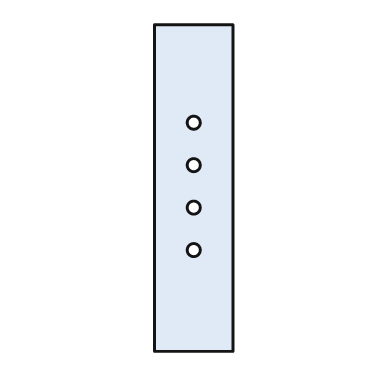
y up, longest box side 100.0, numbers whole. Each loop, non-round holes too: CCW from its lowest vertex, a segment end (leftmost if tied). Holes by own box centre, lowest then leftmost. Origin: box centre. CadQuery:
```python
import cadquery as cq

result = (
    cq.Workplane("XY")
    .moveTo(-12.0, -50.0)
    .lineTo(12.0, -50.0)
    .lineTo(12.0, 50.0)
    .lineTo(-12.0, 50.0)
    .close()
    .moveTo(0.0, -19.0)
    .circle(2.0)
    .moveTo(0.0, -6.0)
    .circle(2.0)
    .moveTo(0.0, 7.0)
    .circle(2.0)
    .moveTo(0.0, 20.0)
    .circle(2.0)
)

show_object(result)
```